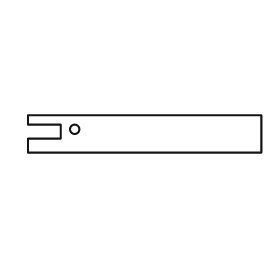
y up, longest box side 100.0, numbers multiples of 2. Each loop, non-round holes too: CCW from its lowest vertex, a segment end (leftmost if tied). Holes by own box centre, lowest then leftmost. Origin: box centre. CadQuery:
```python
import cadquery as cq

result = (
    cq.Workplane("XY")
    .moveTo(-50.0, -8.0)
    .lineTo(50.0, -8.0)
    .lineTo(50.0, 8.0)
    .lineTo(-50.0, 8.0)
    .lineTo(-50.0, 4.0)
    .lineTo(-36.0, 4.0)
    .lineTo(-36.0, -2.0)
    .lineTo(-50.0, -2.0)
    .close()
    .moveTo(-30.0, 2.0)
    .circle(2.0)
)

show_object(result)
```